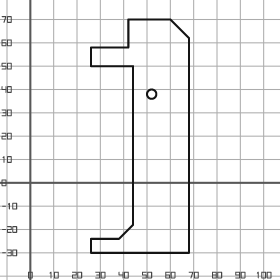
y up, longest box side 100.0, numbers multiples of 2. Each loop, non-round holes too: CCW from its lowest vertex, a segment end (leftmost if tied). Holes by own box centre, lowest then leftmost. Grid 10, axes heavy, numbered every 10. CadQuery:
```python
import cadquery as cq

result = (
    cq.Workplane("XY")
    .moveTo(26.0, -30.0)
    .lineTo(68.0, -30.0)
    .lineTo(68.0, 62.0)
    .lineTo(60.0, 70.0)
    .lineTo(42.0, 70.0)
    .lineTo(42.0, 58.0)
    .lineTo(26.0, 58.0)
    .lineTo(26.0, 50.0)
    .lineTo(44.0, 50.0)
    .lineTo(44.0, -18.0)
    .lineTo(38.0, -24.0)
    .lineTo(26.0, -24.0)
    .close()
    .moveTo(52.0, 38.0)
    .circle(2.0)
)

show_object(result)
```